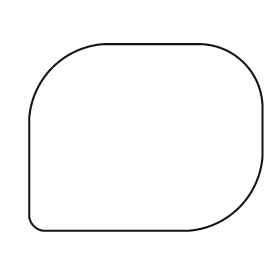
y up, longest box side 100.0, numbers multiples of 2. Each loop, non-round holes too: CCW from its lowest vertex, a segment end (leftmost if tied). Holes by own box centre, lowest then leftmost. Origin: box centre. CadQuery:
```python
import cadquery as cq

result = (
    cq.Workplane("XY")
    .moveTo(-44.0, -40.0)
    .lineTo(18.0, -40.0)
    .threePointArc((40.0, -30.0), (50.0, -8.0))
    .lineTo(50.0, 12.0)
    .threePointArc((42.0, 32.0), (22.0, 40.0))
    .lineTo(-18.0, 40.0)
    .threePointArc((-40.0, 30.0), (-50.0, 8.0))
    .lineTo(-50.0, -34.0)
    .threePointArc((-48.0, -38.0), (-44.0, -40.0))
    .close()
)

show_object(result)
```